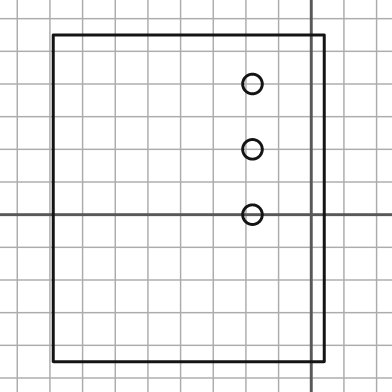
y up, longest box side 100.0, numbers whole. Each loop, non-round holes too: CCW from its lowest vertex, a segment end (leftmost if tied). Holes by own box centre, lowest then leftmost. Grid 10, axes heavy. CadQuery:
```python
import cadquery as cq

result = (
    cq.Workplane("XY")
    .moveTo(-79.0, -45.0)
    .lineTo(4.0, -45.0)
    .lineTo(4.0, 55.0)
    .lineTo(-79.0, 55.0)
    .close()
    .moveTo(-18.0, 0.0)
    .circle(3.0)
    .moveTo(-18.0, 20.0)
    .circle(3.0)
    .moveTo(-18.0, 40.0)
    .circle(3.0)
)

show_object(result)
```